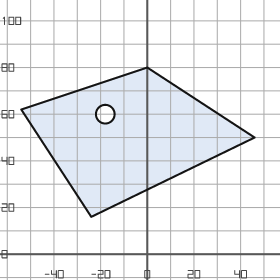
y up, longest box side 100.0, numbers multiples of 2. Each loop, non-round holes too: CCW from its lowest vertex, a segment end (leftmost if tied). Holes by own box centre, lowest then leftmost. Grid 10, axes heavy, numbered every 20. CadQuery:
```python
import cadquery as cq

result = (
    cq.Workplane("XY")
    .moveTo(-24.0, 16.0)
    .lineTo(46.0, 50.0)
    .lineTo(0.0, 80.0)
    .lineTo(-54.0, 62.0)
    .close()
    .moveTo(-18.0, 60.0)
    .circle(4.0)
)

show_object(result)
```